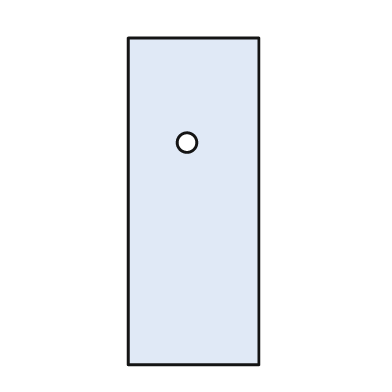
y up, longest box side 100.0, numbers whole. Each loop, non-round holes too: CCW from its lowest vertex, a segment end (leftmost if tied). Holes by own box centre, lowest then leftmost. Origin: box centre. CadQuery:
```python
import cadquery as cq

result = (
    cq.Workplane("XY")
    .moveTo(-20.0, -50.0)
    .lineTo(20.0, -50.0)
    .lineTo(20.0, 50.0)
    .lineTo(-20.0, 50.0)
    .close()
    .moveTo(-2.0, 18.0)
    .circle(3.0)
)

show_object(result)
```